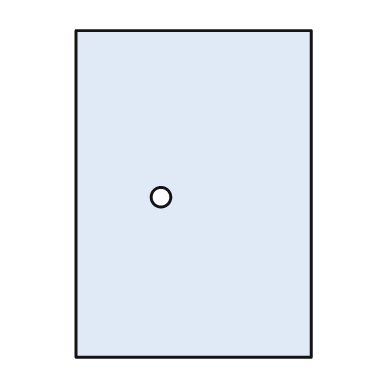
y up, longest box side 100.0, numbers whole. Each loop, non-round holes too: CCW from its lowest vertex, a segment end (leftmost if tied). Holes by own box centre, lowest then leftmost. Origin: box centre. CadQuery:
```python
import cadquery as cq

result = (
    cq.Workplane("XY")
    .moveTo(-36.0, -50.0)
    .lineTo(36.0, -50.0)
    .lineTo(36.0, 50.0)
    .lineTo(-36.0, 50.0)
    .close()
    .moveTo(-10.0, -1.0)
    .circle(3.0)
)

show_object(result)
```